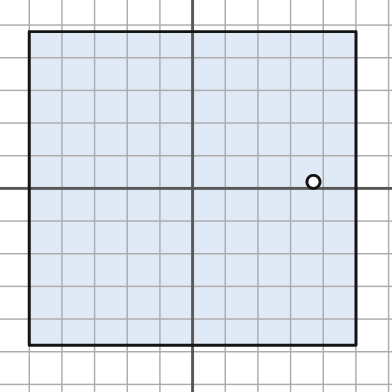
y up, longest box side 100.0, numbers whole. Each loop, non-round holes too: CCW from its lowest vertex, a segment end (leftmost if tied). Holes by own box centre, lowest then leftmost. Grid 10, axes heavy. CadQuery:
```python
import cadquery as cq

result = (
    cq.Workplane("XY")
    .moveTo(-50.0, -48.0)
    .lineTo(50.0, -48.0)
    .lineTo(50.0, 48.0)
    .lineTo(-50.0, 48.0)
    .close()
    .moveTo(37.0, 2.0)
    .circle(2.0)
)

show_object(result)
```